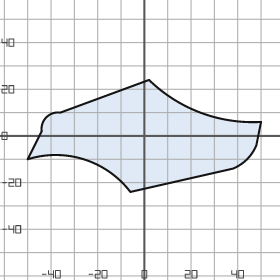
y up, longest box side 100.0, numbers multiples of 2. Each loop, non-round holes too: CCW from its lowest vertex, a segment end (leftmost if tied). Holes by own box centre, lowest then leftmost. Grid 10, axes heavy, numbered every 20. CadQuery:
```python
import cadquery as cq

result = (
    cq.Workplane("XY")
    .moveTo(-6.0, -24.0)
    .lineTo(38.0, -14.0)
    .threePointArc((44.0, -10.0), (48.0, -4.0))
    .lineTo(50.0, 6.0)
    .threePointArc((24.0, 10.0), (2.0, 24.0))
    .lineTo(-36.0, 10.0)
    .threePointArc((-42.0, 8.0), (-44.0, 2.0))
    .lineTo(-50.0, -10.0)
    .threePointArc((-26.0, -10.0), (-6.0, -24.0))
    .close()
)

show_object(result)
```